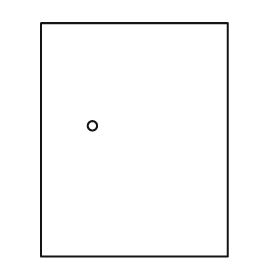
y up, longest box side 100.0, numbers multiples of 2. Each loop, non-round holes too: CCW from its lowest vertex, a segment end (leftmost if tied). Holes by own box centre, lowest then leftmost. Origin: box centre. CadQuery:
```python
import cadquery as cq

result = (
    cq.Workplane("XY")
    .moveTo(-40.0, -50.0)
    .lineTo(40.0, -50.0)
    .lineTo(40.0, 50.0)
    .lineTo(-40.0, 50.0)
    .close()
    .moveTo(-18.0, 6.0)
    .circle(2.0)
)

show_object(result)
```